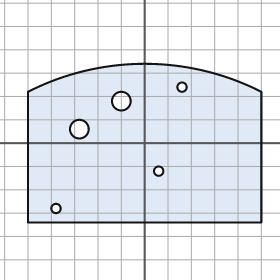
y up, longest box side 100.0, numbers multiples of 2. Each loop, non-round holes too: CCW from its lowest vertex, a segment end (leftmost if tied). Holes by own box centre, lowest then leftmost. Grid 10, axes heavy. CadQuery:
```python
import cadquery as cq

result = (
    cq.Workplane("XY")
    .moveTo(-50.0, -34.0)
    .lineTo(50.0, -34.0)
    .lineTo(50.0, 22.0)
    .threePointArc((0.0, 34.0), (-50.0, 22.0))
    .close()
    .moveTo(-38.0, -28.0)
    .circle(2.0)
    .moveTo(6.0, -12.0)
    .circle(2.0)
    .moveTo(-28.0, 6.0)
    .circle(4.0)
    .moveTo(-10.0, 18.0)
    .circle(4.0)
    .moveTo(16.0, 24.0)
    .circle(2.0)
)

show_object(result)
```